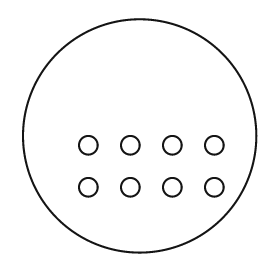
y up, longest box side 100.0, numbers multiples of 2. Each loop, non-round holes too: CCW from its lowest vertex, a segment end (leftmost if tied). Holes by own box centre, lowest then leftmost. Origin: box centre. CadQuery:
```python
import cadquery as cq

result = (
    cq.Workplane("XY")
    .moveTo(0.0, 0.0)
    .circle(50.0)
    .moveTo(-22.0, -22.0)
    .circle(4.0)
    .moveTo(-4.0, -22.0)
    .circle(4.0)
    .moveTo(14.0, -22.0)
    .circle(4.0)
    .moveTo(32.0, -22.0)
    .circle(4.0)
    .moveTo(-22.0, -4.0)
    .circle(4.0)
    .moveTo(-4.0, -4.0)
    .circle(4.0)
    .moveTo(14.0, -4.0)
    .circle(4.0)
    .moveTo(32.0, -4.0)
    .circle(4.0)
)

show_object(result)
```